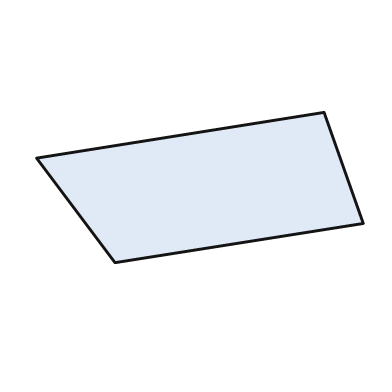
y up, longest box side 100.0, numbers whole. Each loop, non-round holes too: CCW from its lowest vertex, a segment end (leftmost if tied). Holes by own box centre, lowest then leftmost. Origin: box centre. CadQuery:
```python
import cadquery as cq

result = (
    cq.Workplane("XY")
    .moveTo(-26.0, -23.0)
    .lineTo(50.0, -11.0)
    .lineTo(38.0, 23.0)
    .lineTo(-50.0, 9.0)
    .close()
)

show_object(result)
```